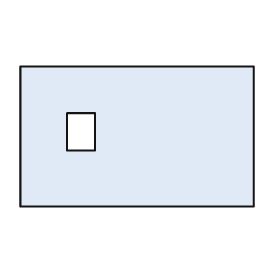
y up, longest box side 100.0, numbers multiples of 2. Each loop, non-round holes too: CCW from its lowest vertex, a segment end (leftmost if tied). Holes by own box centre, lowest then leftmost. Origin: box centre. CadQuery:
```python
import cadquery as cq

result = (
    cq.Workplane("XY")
    .moveTo(-50.0, -30.0)
    .lineTo(50.0, -30.0)
    .lineTo(50.0, 30.0)
    .lineTo(-50.0, 30.0)
    .close()
    .moveTo(-30.0, -6.0)
    .lineTo(-18.0, -6.0)
    .lineTo(-18.0, 10.0)
    .lineTo(-30.0, 10.0)
    .close()
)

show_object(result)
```